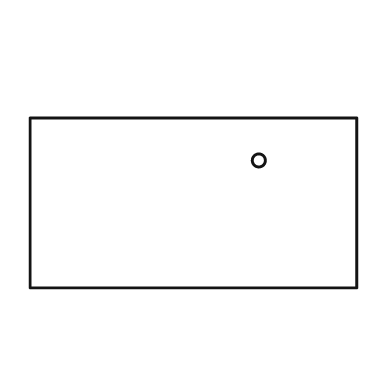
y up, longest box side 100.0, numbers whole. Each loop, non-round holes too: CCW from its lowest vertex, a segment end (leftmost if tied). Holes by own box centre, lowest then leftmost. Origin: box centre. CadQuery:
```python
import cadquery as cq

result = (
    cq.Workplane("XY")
    .moveTo(-50.0, -26.0)
    .lineTo(50.0, -26.0)
    .lineTo(50.0, 26.0)
    .lineTo(-50.0, 26.0)
    .close()
    .moveTo(20.0, 13.0)
    .circle(2.0)
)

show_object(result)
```